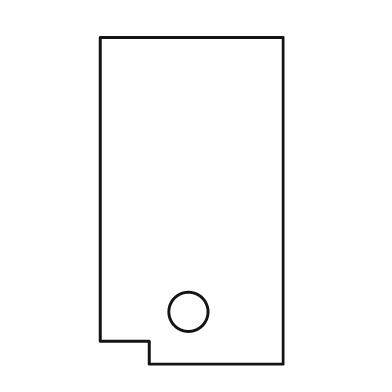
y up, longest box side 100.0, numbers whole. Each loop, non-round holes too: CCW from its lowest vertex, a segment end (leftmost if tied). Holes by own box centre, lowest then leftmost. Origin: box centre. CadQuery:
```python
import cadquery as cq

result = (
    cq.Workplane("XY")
    .moveTo(-13.0, -50.0)
    .lineTo(28.0, -50.0)
    .lineTo(28.0, 50.0)
    .lineTo(-28.0, 50.0)
    .lineTo(-28.0, -43.0)
    .lineTo(-13.0, -43.0)
    .close()
    .moveTo(-1.0, -34.0)
    .circle(6.0)
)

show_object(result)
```